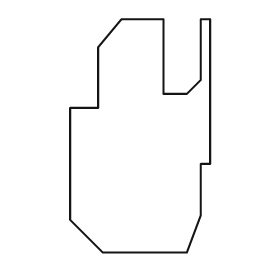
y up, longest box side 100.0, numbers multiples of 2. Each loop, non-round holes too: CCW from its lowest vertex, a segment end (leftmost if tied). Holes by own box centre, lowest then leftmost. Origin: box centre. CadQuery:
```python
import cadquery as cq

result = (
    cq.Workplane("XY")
    .moveTo(-16.0, -50.0)
    .lineTo(20.0, -50.0)
    .lineTo(26.0, -34.0)
    .lineTo(26.0, -12.0)
    .lineTo(30.0, -12.0)
    .lineTo(30.0, 50.0)
    .lineTo(26.0, 50.0)
    .lineTo(26.0, 24.0)
    .lineTo(20.0, 18.0)
    .lineTo(10.0, 18.0)
    .lineTo(10.0, 50.0)
    .lineTo(-8.0, 50.0)
    .lineTo(-18.0, 38.0)
    .lineTo(-18.0, 12.0)
    .lineTo(-30.0, 12.0)
    .lineTo(-30.0, -36.0)
    .close()
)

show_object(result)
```